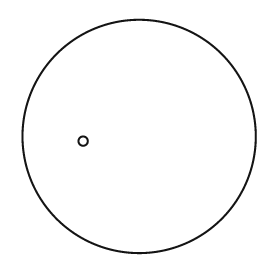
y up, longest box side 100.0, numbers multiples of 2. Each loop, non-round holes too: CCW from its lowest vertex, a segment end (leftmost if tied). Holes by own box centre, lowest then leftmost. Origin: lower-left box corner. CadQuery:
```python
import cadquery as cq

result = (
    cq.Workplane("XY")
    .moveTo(50.0, 50.0)
    .circle(50.0)
    .moveTo(26.0, 48.0)
    .circle(2.0)
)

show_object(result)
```